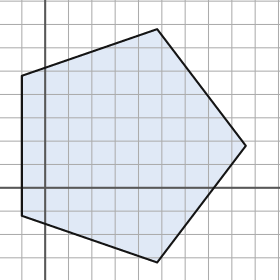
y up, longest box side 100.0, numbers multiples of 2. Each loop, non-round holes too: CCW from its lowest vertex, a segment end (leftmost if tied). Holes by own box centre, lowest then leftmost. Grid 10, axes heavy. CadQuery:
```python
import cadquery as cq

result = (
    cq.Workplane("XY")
    .moveTo(48.0, -32.0)
    .lineTo(86.0, 18.0)
    .lineTo(48.0, 68.0)
    .lineTo(-10.0, 48.0)
    .lineTo(-10.0, -12.0)
    .close()
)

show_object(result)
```